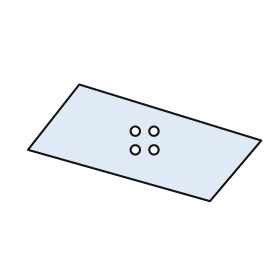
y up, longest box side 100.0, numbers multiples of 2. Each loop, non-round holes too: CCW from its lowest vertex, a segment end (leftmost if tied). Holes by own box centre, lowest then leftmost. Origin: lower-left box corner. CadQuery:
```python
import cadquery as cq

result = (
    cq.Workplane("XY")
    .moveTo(78.0, 0.0)
    .lineTo(100.0, 26.0)
    .lineTo(22.0, 50.0)
    .lineTo(0.0, 22.0)
    .close()
    .moveTo(46.0, 22.0)
    .circle(2.0)
    .moveTo(54.0, 22.0)
    .circle(2.0)
    .moveTo(46.0, 30.0)
    .circle(2.0)
    .moveTo(54.0, 30.0)
    .circle(2.0)
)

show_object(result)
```